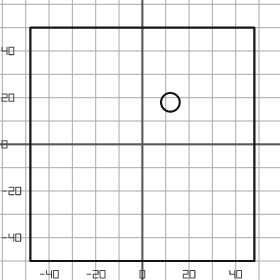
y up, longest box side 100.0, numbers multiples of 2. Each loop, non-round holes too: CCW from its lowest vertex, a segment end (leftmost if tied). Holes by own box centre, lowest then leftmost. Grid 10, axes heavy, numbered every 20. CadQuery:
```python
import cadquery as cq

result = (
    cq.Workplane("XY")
    .moveTo(-48.0, -50.0)
    .lineTo(48.0, -50.0)
    .lineTo(48.0, 50.0)
    .lineTo(-48.0, 50.0)
    .close()
    .moveTo(12.0, 18.0)
    .circle(4.0)
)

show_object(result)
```